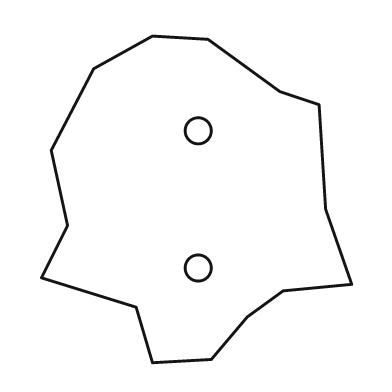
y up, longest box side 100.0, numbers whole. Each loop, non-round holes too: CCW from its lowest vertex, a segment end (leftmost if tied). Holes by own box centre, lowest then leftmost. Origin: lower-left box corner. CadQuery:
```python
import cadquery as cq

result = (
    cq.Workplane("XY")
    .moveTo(34.0, 0.0)
    .lineTo(52.0, 1.0)
    .lineTo(63.0, 14.0)
    .lineTo(74.0, 22.0)
    .lineTo(95.0, 24.0)
    .lineTo(87.0, 47.0)
    .lineTo(85.0, 79.0)
    .lineTo(73.0, 83.0)
    .lineTo(51.0, 99.0)
    .lineTo(34.0, 100.0)
    .lineTo(16.0, 90.0)
    .lineTo(3.0, 65.0)
    .lineTo(8.0, 42.0)
    .lineTo(0.0, 26.0)
    .lineTo(29.0, 17.0)
    .close()
    .moveTo(48.0, 29.0)
    .circle(4.0)
    .moveTo(48.0, 71.0)
    .circle(4.0)
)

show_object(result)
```